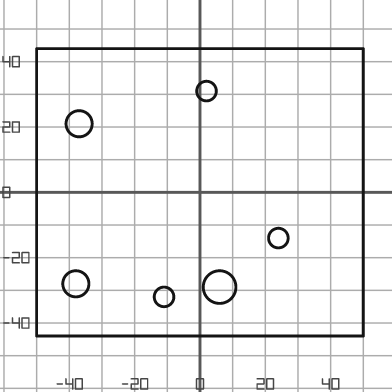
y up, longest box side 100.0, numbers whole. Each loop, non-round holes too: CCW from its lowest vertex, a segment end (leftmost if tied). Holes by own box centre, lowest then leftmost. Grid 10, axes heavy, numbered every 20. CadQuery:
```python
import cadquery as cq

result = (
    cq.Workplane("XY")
    .moveTo(-50.0, -44.0)
    .lineTo(50.0, -44.0)
    .lineTo(50.0, 44.0)
    .lineTo(-50.0, 44.0)
    .close()
    .moveTo(-11.0, -32.0)
    .circle(3.0)
    .moveTo(6.0, -29.0)
    .circle(5.0)
    .moveTo(-38.0, -28.0)
    .circle(4.0)
    .moveTo(24.0, -14.0)
    .circle(3.0)
    .moveTo(-37.0, 21.0)
    .circle(4.0)
    .moveTo(2.0, 31.0)
    .circle(3.0)
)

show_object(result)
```